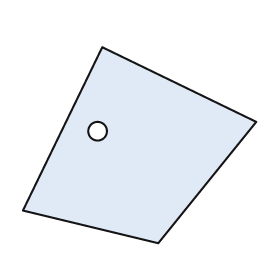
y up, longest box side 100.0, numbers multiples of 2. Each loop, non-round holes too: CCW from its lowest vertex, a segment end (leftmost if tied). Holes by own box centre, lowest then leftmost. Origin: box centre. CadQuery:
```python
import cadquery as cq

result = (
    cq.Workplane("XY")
    .moveTo(8.0, -42.0)
    .lineTo(50.0, 10.0)
    .lineTo(-16.0, 42.0)
    .lineTo(-50.0, -28.0)
    .close()
    .moveTo(-18.0, 6.0)
    .circle(4.0)
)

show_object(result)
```